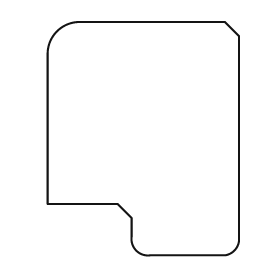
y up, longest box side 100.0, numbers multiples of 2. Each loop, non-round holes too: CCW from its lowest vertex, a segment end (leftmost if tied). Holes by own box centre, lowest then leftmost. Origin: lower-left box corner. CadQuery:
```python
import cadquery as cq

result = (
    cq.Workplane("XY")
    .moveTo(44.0, 0.0)
    .lineTo(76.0, 0.0)
    .threePointArc((80.0, 2.0), (82.0, 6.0))
    .lineTo(82.0, 94.0)
    .lineTo(76.0, 100.0)
    .lineTo(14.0, 100.0)
    .threePointArc((4.0, 96.0), (0.0, 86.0))
    .lineTo(0.0, 22.0)
    .lineTo(30.0, 22.0)
    .lineTo(36.0, 16.0)
    .lineTo(36.0, 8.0)
    .threePointArc((38.0, 2.0), (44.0, 0.0))
    .close()
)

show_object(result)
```